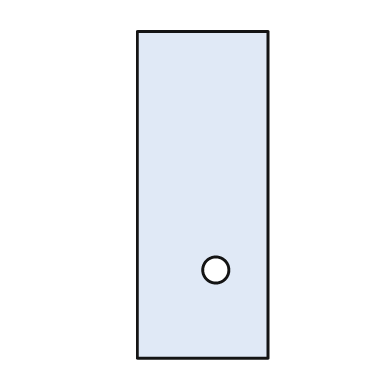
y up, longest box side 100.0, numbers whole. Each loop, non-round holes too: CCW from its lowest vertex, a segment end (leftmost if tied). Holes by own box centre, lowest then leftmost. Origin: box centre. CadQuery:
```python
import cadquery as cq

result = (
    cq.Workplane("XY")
    .moveTo(-20.0, -50.0)
    .lineTo(20.0, -50.0)
    .lineTo(20.0, 50.0)
    .lineTo(-20.0, 50.0)
    .close()
    .moveTo(4.0, -23.0)
    .circle(4.0)
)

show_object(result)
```